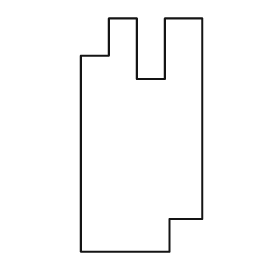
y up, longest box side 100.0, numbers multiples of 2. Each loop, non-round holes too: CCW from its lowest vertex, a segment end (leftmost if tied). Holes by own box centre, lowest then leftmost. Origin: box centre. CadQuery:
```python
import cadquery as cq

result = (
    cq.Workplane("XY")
    .moveTo(-26.0, -50.0)
    .lineTo(12.0, -50.0)
    .lineTo(12.0, -36.0)
    .lineTo(26.0, -36.0)
    .lineTo(26.0, 50.0)
    .lineTo(10.0, 50.0)
    .lineTo(10.0, 24.0)
    .lineTo(-2.0, 24.0)
    .lineTo(-2.0, 50.0)
    .lineTo(-14.0, 50.0)
    .lineTo(-14.0, 34.0)
    .lineTo(-26.0, 34.0)
    .close()
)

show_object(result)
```